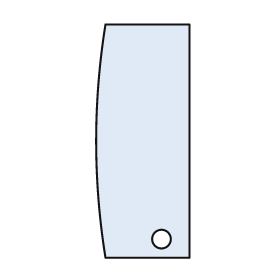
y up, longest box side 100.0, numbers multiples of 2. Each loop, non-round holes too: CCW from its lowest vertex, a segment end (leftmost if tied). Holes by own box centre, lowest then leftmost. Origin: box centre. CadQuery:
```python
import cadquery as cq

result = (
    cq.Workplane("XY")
    .moveTo(-16.0, -50.0)
    .lineTo(20.0, -50.0)
    .lineTo(20.0, 50.0)
    .lineTo(-16.0, 50.0)
    .threePointArc((-20.0, 0.0), (-16.0, -50.0))
    .close()
    .moveTo(8.0, -42.0)
    .circle(4.0)
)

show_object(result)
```